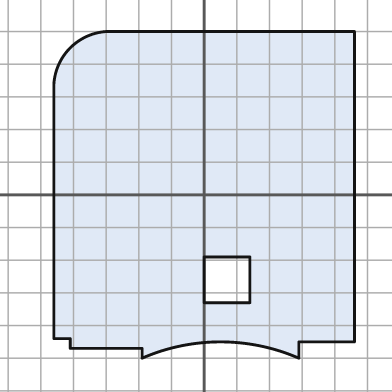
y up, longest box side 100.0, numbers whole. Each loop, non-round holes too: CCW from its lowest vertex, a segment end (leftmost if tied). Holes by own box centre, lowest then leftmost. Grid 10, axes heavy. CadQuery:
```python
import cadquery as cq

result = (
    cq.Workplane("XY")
    .moveTo(-19.0, -50.0)
    .threePointArc((5.0, -45.0), (29.0, -50.0))
    .lineTo(29.0, -45.0)
    .lineTo(46.0, -45.0)
    .lineTo(46.0, 50.0)
    .lineTo(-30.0, 50.0)
    .threePointArc((-41.0, 45.0), (-46.0, 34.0))
    .lineTo(-46.0, -44.0)
    .lineTo(-41.0, -44.0)
    .lineTo(-41.0, -47.0)
    .lineTo(-19.0, -47.0)
    .close()
    .moveTo(0.0, -33.0)
    .lineTo(14.0, -33.0)
    .lineTo(14.0, -19.0)
    .lineTo(0.0, -19.0)
    .close()
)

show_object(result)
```